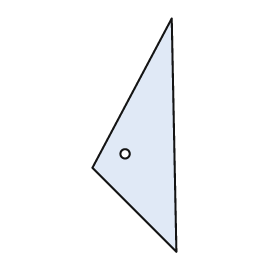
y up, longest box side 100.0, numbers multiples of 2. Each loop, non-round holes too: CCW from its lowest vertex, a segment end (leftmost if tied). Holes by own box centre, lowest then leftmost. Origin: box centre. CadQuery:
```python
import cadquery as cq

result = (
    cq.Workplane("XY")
    .moveTo(18.0, -50.0)
    .lineTo(16.0, 50.0)
    .lineTo(-18.0, -14.0)
    .close()
    .moveTo(-4.0, -8.0)
    .circle(2.0)
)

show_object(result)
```